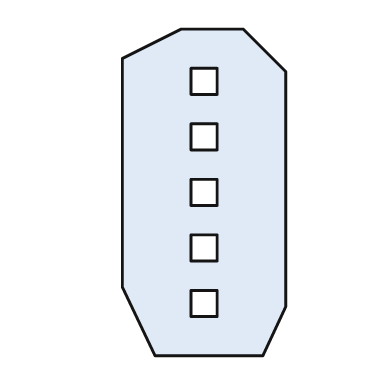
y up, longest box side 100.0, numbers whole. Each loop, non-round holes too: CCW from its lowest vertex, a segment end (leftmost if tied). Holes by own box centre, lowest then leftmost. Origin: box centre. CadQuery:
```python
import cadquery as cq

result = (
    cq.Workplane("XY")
    .moveTo(-15.0, -50.0)
    .lineTo(18.0, -50.0)
    .lineTo(25.0, -35.0)
    .lineTo(25.0, 37.0)
    .lineTo(12.0, 50.0)
    .lineTo(-7.0, 50.0)
    .lineTo(-25.0, 41.0)
    .lineTo(-25.0, -29.0)
    .close()
    .moveTo(-4.0, -38.0)
    .lineTo(4.0, -38.0)
    .lineTo(4.0, -30.0)
    .lineTo(-4.0, -30.0)
    .close()
    .moveTo(-4.0, -21.0)
    .lineTo(4.0, -21.0)
    .lineTo(4.0, -13.0)
    .lineTo(-4.0, -13.0)
    .close()
    .moveTo(-4.0, -4.0)
    .lineTo(4.0, -4.0)
    .lineTo(4.0, 4.0)
    .lineTo(-4.0, 4.0)
    .close()
    .moveTo(-4.0, 13.0)
    .lineTo(4.0, 13.0)
    .lineTo(4.0, 21.0)
    .lineTo(-4.0, 21.0)
    .close()
    .moveTo(-4.0, 30.0)
    .lineTo(4.0, 30.0)
    .lineTo(4.0, 38.0)
    .lineTo(-4.0, 38.0)
    .close()
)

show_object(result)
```